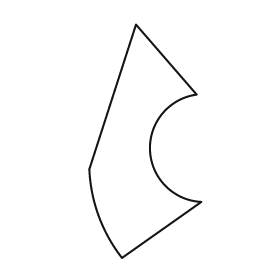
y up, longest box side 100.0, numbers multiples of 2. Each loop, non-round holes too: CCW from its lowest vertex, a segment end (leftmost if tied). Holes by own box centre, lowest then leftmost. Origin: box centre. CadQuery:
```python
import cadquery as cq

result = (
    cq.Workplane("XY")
    .moveTo(-10.0, -50.0)
    .lineTo(24.0, -26.0)
    .threePointArc((2.0, -4.0), (22.0, 20.0))
    .lineTo(-4.0, 50.0)
    .lineTo(-24.0, -12.0)
    .threePointArc((-20.0, -32.0), (-10.0, -50.0))
    .close()
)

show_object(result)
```